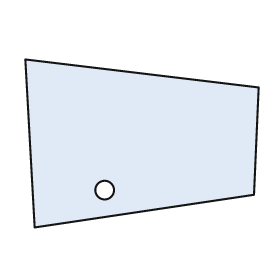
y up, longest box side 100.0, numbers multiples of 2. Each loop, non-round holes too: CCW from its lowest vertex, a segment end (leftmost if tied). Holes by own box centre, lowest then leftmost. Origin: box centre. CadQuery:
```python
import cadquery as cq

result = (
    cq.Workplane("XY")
    .moveTo(-46.0, -36.0)
    .lineTo(48.0, -22.0)
    .lineTo(50.0, 24.0)
    .lineTo(-50.0, 36.0)
    .close()
    .moveTo(-16.0, -20.0)
    .circle(4.0)
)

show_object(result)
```